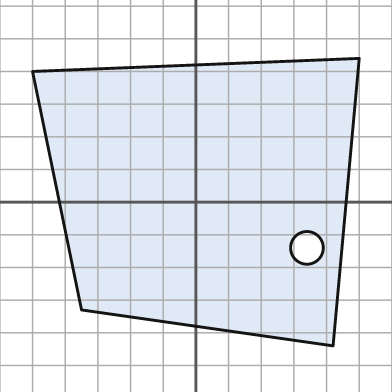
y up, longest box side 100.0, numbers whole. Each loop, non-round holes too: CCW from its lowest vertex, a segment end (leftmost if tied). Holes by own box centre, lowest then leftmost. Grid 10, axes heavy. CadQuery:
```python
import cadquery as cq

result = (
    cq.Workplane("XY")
    .moveTo(42.0, -44.0)
    .lineTo(50.0, 44.0)
    .lineTo(-50.0, 40.0)
    .lineTo(-35.0, -33.0)
    .close()
    .moveTo(34.0, -14.0)
    .circle(5.0)
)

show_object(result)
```